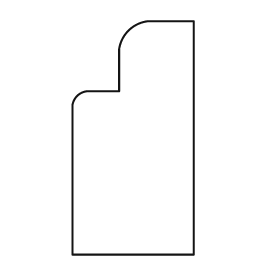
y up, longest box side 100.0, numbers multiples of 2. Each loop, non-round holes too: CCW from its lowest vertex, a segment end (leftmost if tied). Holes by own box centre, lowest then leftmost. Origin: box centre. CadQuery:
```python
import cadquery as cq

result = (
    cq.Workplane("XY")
    .moveTo(-26.0, -50.0)
    .lineTo(26.0, -50.0)
    .lineTo(26.0, 50.0)
    .lineTo(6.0, 50.0)
    .threePointArc((-2.0, 46.0), (-6.0, 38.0))
    .lineTo(-6.0, 20.0)
    .lineTo(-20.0, 20.0)
    .threePointArc((-24.0, 18.0), (-26.0, 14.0))
    .close()
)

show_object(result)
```